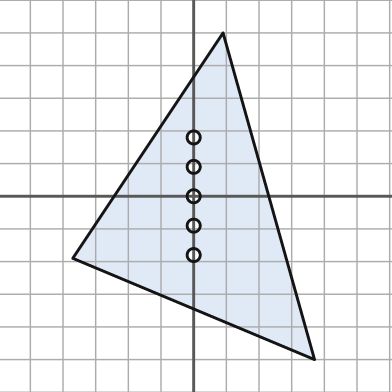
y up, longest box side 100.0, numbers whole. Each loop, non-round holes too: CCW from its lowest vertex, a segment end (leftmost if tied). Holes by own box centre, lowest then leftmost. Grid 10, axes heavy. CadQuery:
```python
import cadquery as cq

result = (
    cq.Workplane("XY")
    .moveTo(37.0, -50.0)
    .lineTo(9.0, 50.0)
    .lineTo(-37.0, -19.0)
    .close()
    .moveTo(0.0, -18.0)
    .circle(2.0)
    .moveTo(0.0, -9.0)
    .circle(2.0)
    .moveTo(0.0, 0.0)
    .circle(2.0)
    .moveTo(0.0, 9.0)
    .circle(2.0)
    .moveTo(0.0, 18.0)
    .circle(2.0)
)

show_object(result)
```